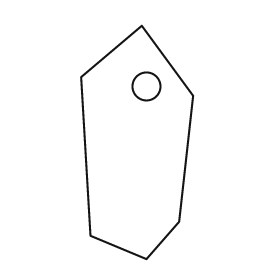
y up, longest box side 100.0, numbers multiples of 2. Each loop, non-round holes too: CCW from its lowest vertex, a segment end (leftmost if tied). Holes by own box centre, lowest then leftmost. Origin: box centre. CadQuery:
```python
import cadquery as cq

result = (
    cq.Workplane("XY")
    .moveTo(4.0, -50.0)
    .lineTo(18.0, -34.0)
    .lineTo(24.0, 20.0)
    .lineTo(2.0, 50.0)
    .lineTo(-24.0, 28.0)
    .lineTo(-20.0, -40.0)
    .close()
    .moveTo(4.0, 24.0)
    .circle(6.0)
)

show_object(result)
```